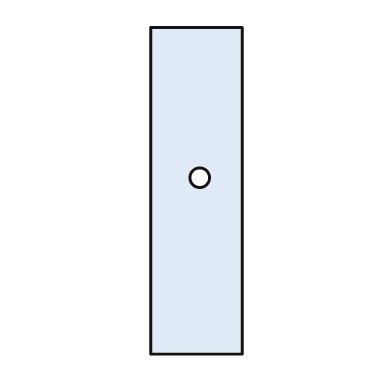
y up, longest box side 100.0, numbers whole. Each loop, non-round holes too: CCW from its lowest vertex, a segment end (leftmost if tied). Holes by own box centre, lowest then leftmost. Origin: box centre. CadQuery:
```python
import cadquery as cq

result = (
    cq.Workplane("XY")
    .moveTo(-14.0, -50.0)
    .lineTo(14.0, -50.0)
    .lineTo(14.0, 50.0)
    .lineTo(-14.0, 50.0)
    .close()
    .moveTo(1.0, 4.0)
    .circle(3.0)
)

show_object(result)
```